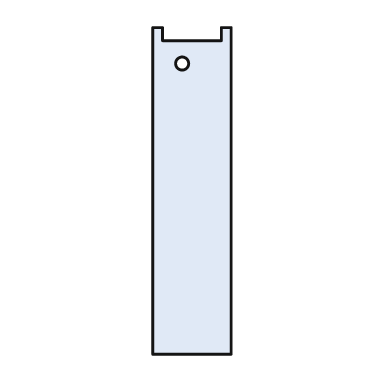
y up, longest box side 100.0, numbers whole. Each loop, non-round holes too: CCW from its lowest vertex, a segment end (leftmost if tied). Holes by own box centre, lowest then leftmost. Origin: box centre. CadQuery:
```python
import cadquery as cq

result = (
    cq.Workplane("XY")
    .moveTo(-12.0, -50.0)
    .lineTo(12.0, -50.0)
    .lineTo(12.0, 50.0)
    .lineTo(9.0, 50.0)
    .lineTo(9.0, 46.0)
    .lineTo(-9.0, 46.0)
    .lineTo(-9.0, 50.0)
    .lineTo(-12.0, 50.0)
    .close()
    .moveTo(-3.0, 39.0)
    .circle(2.0)
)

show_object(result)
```